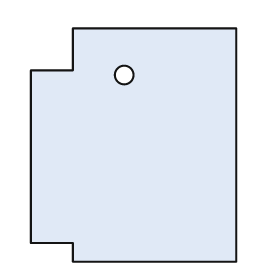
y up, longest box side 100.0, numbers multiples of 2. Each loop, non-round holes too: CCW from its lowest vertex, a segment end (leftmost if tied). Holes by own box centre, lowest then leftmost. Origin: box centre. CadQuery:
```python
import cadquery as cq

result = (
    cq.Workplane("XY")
    .moveTo(-26.0, -50.0)
    .lineTo(44.0, -50.0)
    .lineTo(44.0, 50.0)
    .lineTo(-26.0, 50.0)
    .lineTo(-26.0, 32.0)
    .lineTo(-44.0, 32.0)
    .lineTo(-44.0, -42.0)
    .lineTo(-26.0, -42.0)
    .close()
    .moveTo(-4.0, 30.0)
    .circle(4.0)
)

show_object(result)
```